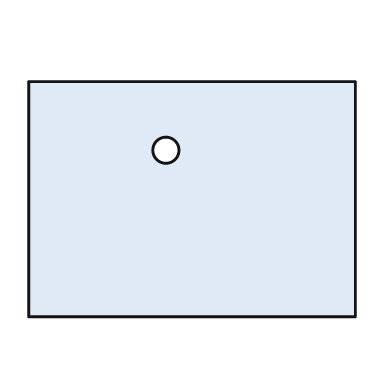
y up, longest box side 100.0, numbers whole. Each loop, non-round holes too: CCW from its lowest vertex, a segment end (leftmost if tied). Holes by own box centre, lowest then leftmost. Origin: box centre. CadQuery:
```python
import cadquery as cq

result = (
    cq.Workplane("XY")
    .moveTo(-50.0, -36.0)
    .lineTo(50.0, -36.0)
    .lineTo(50.0, 36.0)
    .lineTo(-50.0, 36.0)
    .close()
    .moveTo(-8.0, 15.0)
    .circle(4.0)
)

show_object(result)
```